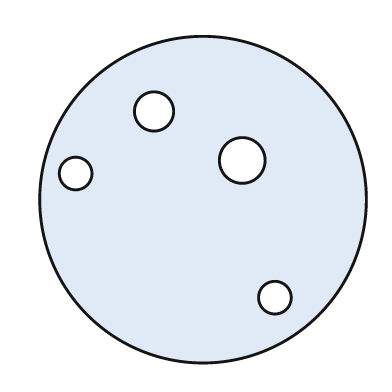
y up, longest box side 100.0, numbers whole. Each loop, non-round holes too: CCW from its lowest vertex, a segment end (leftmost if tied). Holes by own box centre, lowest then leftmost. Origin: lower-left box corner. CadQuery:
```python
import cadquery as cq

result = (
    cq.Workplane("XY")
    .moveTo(50.0, 50.0)
    .circle(50.0)
    .moveTo(72.0, 20.0)
    .circle(5.0)
    .moveTo(11.0, 58.0)
    .circle(5.0)
    .moveTo(62.0, 62.0)
    .circle(7.0)
    .moveTo(35.0, 77.0)
    .circle(6.0)
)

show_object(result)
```